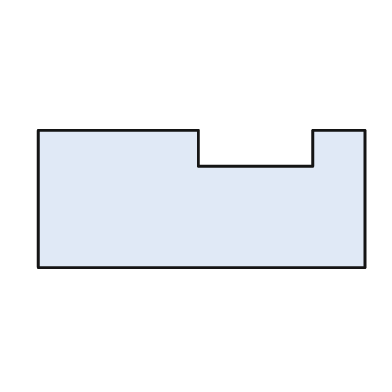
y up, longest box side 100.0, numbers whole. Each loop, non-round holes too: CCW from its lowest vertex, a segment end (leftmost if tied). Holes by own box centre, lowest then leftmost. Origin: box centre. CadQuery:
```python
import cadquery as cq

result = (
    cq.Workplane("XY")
    .moveTo(-50.0, -21.0)
    .lineTo(50.0, -21.0)
    .lineTo(50.0, 21.0)
    .lineTo(34.0, 21.0)
    .lineTo(34.0, 10.0)
    .lineTo(-1.0, 10.0)
    .lineTo(-1.0, 21.0)
    .lineTo(-50.0, 21.0)
    .close()
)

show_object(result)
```